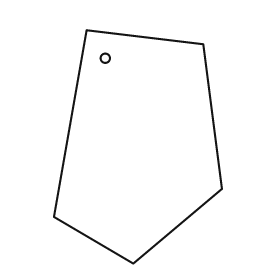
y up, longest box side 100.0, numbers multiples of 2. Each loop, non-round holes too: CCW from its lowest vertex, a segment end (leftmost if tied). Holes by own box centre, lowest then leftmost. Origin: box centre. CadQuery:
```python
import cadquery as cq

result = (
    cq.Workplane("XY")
    .moveTo(-2.0, -50.0)
    .lineTo(36.0, -18.0)
    .lineTo(28.0, 44.0)
    .lineTo(-22.0, 50.0)
    .lineTo(-36.0, -30.0)
    .close()
    .moveTo(-14.0, 38.0)
    .circle(2.0)
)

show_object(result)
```